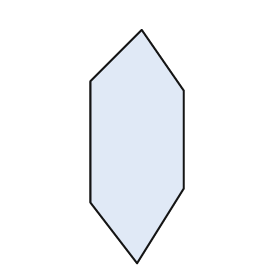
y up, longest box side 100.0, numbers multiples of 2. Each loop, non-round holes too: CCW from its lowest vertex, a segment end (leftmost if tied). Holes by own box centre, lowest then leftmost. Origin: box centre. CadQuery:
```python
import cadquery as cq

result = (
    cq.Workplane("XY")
    .moveTo(0.0, -50.0)
    .lineTo(20.0, -18.0)
    .lineTo(20.0, 24.0)
    .lineTo(2.0, 50.0)
    .lineTo(-20.0, 28.0)
    .lineTo(-20.0, -24.0)
    .close()
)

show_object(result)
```